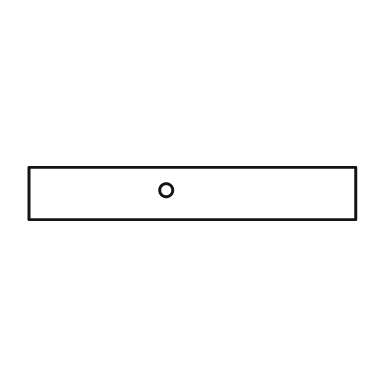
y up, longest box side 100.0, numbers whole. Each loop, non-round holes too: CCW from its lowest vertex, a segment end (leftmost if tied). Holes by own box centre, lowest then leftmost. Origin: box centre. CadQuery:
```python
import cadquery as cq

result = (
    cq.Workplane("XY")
    .moveTo(-50.0, -8.0)
    .lineTo(50.0, -8.0)
    .lineTo(50.0, 8.0)
    .lineTo(-50.0, 8.0)
    .close()
    .moveTo(-8.0, 1.0)
    .circle(2.0)
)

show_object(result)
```